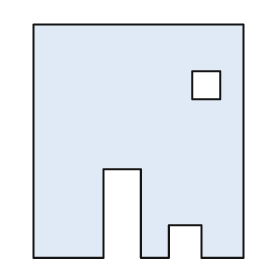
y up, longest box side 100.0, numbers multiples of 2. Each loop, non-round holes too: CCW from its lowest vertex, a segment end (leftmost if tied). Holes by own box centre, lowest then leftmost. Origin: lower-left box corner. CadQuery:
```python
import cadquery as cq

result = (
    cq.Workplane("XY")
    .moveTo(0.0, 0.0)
    .lineTo(30.0, 0.0)
    .lineTo(30.0, 38.0)
    .lineTo(46.0, 38.0)
    .lineTo(46.0, 0.0)
    .lineTo(58.0, 0.0)
    .lineTo(58.0, 14.0)
    .lineTo(72.0, 14.0)
    .lineTo(72.0, 0.0)
    .lineTo(90.0, 0.0)
    .lineTo(90.0, 100.0)
    .lineTo(0.0, 100.0)
    .close()
    .moveTo(68.0, 68.0)
    .lineTo(80.0, 68.0)
    .lineTo(80.0, 80.0)
    .lineTo(68.0, 80.0)
    .close()
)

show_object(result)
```